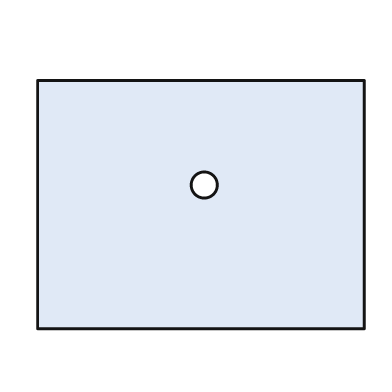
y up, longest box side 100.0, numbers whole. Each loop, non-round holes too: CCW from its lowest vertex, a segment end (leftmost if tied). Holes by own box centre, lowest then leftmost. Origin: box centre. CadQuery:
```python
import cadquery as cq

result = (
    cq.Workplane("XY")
    .moveTo(-50.0, -38.0)
    .lineTo(50.0, -38.0)
    .lineTo(50.0, 38.0)
    .lineTo(-50.0, 38.0)
    .close()
    .moveTo(1.0, 6.0)
    .circle(4.0)
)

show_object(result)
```